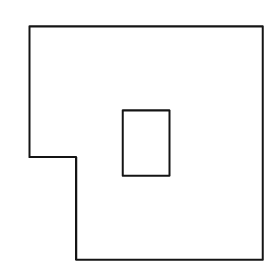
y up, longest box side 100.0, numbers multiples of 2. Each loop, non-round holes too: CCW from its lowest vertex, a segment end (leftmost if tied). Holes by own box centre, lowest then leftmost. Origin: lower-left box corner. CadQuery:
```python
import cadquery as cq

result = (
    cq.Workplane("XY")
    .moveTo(20.0, 0.0)
    .lineTo(100.0, 0.0)
    .lineTo(100.0, 100.0)
    .lineTo(0.0, 100.0)
    .lineTo(0.0, 44.0)
    .lineTo(20.0, 44.0)
    .close()
    .moveTo(40.0, 36.0)
    .lineTo(60.0, 36.0)
    .lineTo(60.0, 64.0)
    .lineTo(40.0, 64.0)
    .close()
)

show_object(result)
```